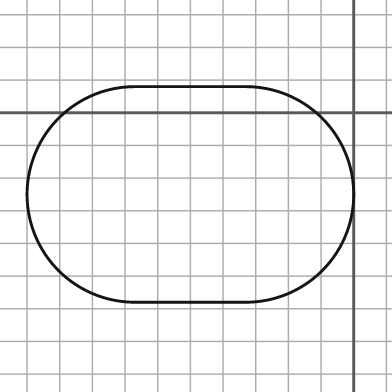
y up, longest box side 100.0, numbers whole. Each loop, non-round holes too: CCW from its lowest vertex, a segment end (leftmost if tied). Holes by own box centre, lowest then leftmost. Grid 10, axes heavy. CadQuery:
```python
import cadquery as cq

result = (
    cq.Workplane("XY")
    .moveTo(-67.0, -58.0)
    .lineTo(-33.0, -58.0)
    .threePointArc((0.0, -25.0), (-33.0, 8.0))
    .lineTo(-67.0, 8.0)
    .threePointArc((-100.0, -25.0), (-67.0, -58.0))
    .close()
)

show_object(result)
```